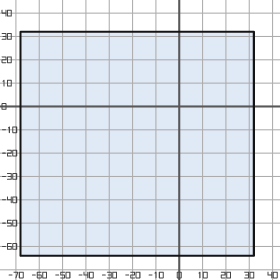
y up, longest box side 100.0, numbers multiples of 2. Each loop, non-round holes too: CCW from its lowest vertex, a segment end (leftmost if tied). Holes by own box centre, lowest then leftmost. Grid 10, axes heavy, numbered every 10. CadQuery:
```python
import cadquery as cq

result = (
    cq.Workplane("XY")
    .moveTo(-68.0, -64.0)
    .lineTo(32.0, -64.0)
    .lineTo(32.0, 32.0)
    .lineTo(-68.0, 32.0)
    .close()
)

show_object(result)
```